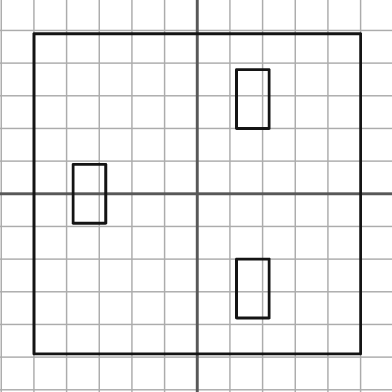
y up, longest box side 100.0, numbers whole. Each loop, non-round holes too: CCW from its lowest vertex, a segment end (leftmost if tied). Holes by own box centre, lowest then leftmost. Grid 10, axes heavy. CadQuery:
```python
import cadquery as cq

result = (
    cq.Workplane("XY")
    .moveTo(-50.0, -49.0)
    .lineTo(50.0, -49.0)
    .lineTo(50.0, 49.0)
    .lineTo(-50.0, 49.0)
    .close()
    .moveTo(12.0, -38.0)
    .lineTo(22.0, -38.0)
    .lineTo(22.0, -20.0)
    .lineTo(12.0, -20.0)
    .close()
    .moveTo(-38.0, -9.0)
    .lineTo(-28.0, -9.0)
    .lineTo(-28.0, 9.0)
    .lineTo(-38.0, 9.0)
    .close()
    .moveTo(12.0, 20.0)
    .lineTo(22.0, 20.0)
    .lineTo(22.0, 38.0)
    .lineTo(12.0, 38.0)
    .close()
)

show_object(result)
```